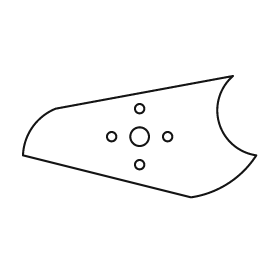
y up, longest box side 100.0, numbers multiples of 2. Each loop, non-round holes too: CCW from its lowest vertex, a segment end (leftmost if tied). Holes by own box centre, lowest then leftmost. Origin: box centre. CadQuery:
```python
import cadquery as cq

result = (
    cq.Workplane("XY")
    .moveTo(22.0, -26.0)
    .threePointArc((38.0, -20.0), (50.0, -8.0))
    .threePointArc((34.0, 6.0), (40.0, 26.0))
    .lineTo(-36.0, 12.0)
    .threePointArc((-46.0, 4.0), (-50.0, -8.0))
    .close()
    .moveTo(0.0, -12.0)
    .circle(2.0)
    .moveTo(-12.0, 0.0)
    .circle(2.0)
    .moveTo(0.0, 0.0)
    .circle(4.0)
    .moveTo(12.0, 0.0)
    .circle(2.0)
    .moveTo(0.0, 12.0)
    .circle(2.0)
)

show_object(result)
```